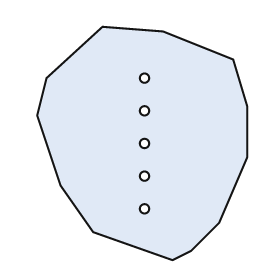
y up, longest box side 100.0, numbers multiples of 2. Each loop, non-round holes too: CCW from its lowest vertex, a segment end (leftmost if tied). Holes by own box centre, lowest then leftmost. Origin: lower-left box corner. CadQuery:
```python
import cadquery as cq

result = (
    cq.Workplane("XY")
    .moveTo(58.0, 0.0)
    .lineTo(66.0, 4.0)
    .lineTo(78.0, 16.0)
    .lineTo(90.0, 44.0)
    .lineTo(90.0, 66.0)
    .lineTo(84.0, 86.0)
    .lineTo(54.0, 98.0)
    .lineTo(28.0, 100.0)
    .lineTo(4.0, 78.0)
    .lineTo(0.0, 62.0)
    .lineTo(10.0, 32.0)
    .lineTo(24.0, 12.0)
    .close()
    .moveTo(46.0, 22.0)
    .circle(2.0)
    .moveTo(46.0, 36.0)
    .circle(2.0)
    .moveTo(46.0, 50.0)
    .circle(2.0)
    .moveTo(46.0, 64.0)
    .circle(2.0)
    .moveTo(46.0, 78.0)
    .circle(2.0)
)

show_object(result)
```